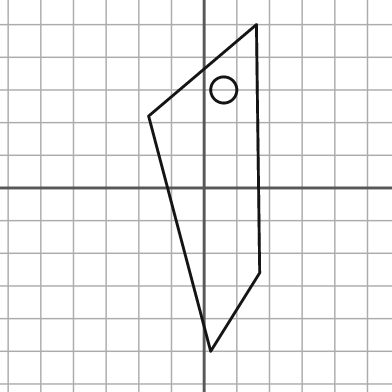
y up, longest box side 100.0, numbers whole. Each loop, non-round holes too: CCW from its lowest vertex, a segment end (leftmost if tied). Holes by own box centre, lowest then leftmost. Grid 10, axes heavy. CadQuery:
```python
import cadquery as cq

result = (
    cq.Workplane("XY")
    .moveTo(2.0, -50.0)
    .lineTo(17.0, -26.0)
    .lineTo(16.0, 50.0)
    .lineTo(-17.0, 22.0)
    .close()
    .moveTo(6.0, 30.0)
    .circle(4.0)
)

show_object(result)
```